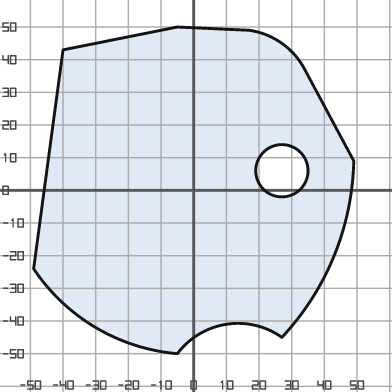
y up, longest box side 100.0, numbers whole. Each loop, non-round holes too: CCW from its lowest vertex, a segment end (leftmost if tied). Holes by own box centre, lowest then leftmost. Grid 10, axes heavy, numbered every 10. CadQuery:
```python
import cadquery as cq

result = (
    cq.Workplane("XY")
    .moveTo(-5.0, -50.0)
    .threePointArc((10.0, -41.0), (27.0, -45.0))
    .threePointArc((43.0, -20.0), (49.0, 9.0))
    .lineTo(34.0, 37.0)
    .threePointArc((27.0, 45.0), (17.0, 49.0))
    .lineTo(-5.0, 50.0)
    .lineTo(-40.0, 43.0)
    .lineTo(-49.0, -24.0)
    .threePointArc((-30.0, -42.0), (-5.0, -50.0))
    .close()
    .moveTo(27.0, 6.0)
    .circle(8.0)
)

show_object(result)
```